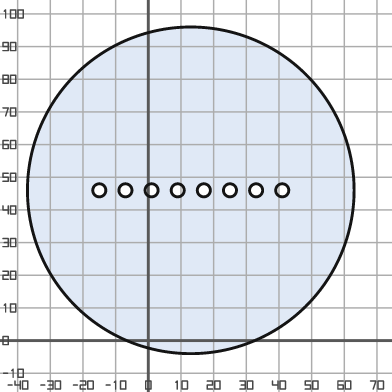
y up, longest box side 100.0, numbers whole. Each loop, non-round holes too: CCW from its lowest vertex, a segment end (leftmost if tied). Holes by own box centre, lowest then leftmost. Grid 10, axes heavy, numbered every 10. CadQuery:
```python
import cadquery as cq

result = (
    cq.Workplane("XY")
    .moveTo(13.0, 46.0)
    .circle(50.0)
    .moveTo(-15.0, 46.0)
    .circle(2.0)
    .moveTo(-7.0, 46.0)
    .circle(2.0)
    .moveTo(1.0, 46.0)
    .circle(2.0)
    .moveTo(9.0, 46.0)
    .circle(2.0)
    .moveTo(17.0, 46.0)
    .circle(2.0)
    .moveTo(25.0, 46.0)
    .circle(2.0)
    .moveTo(33.0, 46.0)
    .circle(2.0)
    .moveTo(41.0, 46.0)
    .circle(2.0)
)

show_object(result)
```